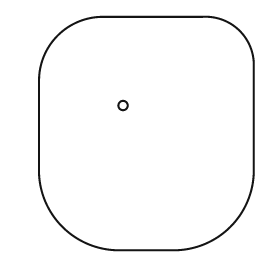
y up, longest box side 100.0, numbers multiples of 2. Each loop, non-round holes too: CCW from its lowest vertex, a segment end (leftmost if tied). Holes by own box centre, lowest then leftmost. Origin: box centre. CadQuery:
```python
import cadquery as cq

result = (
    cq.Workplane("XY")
    .moveTo(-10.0, -50.0)
    .lineTo(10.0, -50.0)
    .threePointArc((36.0, -40.0), (46.0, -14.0))
    .lineTo(46.0, 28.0)
    .threePointArc((40.0, 44.0), (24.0, 50.0))
    .lineTo(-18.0, 50.0)
    .threePointArc((-38.0, 42.0), (-46.0, 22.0))
    .lineTo(-46.0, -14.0)
    .threePointArc((-36.0, -40.0), (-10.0, -50.0))
    .close()
    .moveTo(-10.0, 12.0)
    .circle(2.0)
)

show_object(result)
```